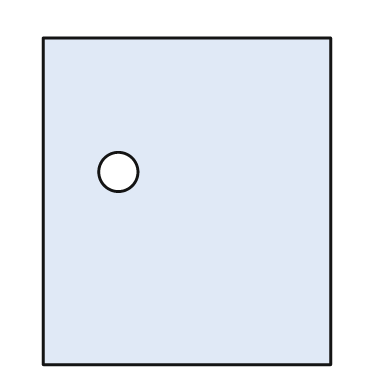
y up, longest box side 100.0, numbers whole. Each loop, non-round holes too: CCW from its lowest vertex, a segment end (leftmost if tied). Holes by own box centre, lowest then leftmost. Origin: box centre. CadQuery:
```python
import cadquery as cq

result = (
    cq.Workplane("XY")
    .moveTo(-44.0, -50.0)
    .lineTo(44.0, -50.0)
    .lineTo(44.0, 50.0)
    .lineTo(-44.0, 50.0)
    .close()
    .moveTo(-21.0, 9.0)
    .circle(6.0)
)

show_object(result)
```